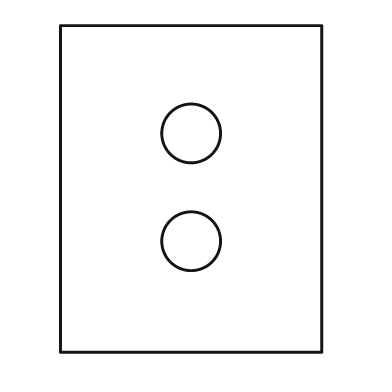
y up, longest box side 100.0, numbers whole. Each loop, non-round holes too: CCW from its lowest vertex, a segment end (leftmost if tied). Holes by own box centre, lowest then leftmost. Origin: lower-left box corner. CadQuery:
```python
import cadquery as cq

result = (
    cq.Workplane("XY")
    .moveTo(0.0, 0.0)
    .lineTo(80.0, 0.0)
    .lineTo(80.0, 100.0)
    .lineTo(0.0, 100.0)
    .close()
    .moveTo(40.0, 34.0)
    .circle(9.0)
    .moveTo(40.0, 67.0)
    .circle(9.0)
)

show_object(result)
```